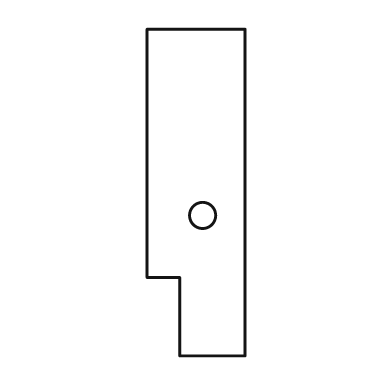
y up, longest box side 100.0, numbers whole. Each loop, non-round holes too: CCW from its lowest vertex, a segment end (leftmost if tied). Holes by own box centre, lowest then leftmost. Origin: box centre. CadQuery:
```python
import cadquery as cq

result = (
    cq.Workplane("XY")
    .moveTo(-5.0, -50.0)
    .lineTo(15.0, -50.0)
    .lineTo(15.0, 50.0)
    .lineTo(-15.0, 50.0)
    .lineTo(-15.0, -26.0)
    .lineTo(-5.0, -26.0)
    .close()
    .moveTo(2.0, -7.0)
    .circle(4.0)
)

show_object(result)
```